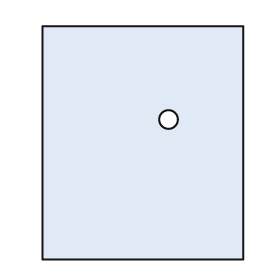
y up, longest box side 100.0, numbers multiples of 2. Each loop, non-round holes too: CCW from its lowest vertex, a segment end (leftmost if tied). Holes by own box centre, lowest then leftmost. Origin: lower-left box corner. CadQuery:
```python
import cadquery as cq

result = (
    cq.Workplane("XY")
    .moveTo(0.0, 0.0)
    .lineTo(86.0, 0.0)
    .lineTo(86.0, 100.0)
    .lineTo(0.0, 100.0)
    .close()
    .moveTo(54.0, 60.0)
    .circle(4.0)
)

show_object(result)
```